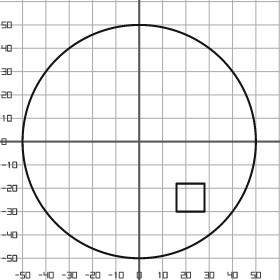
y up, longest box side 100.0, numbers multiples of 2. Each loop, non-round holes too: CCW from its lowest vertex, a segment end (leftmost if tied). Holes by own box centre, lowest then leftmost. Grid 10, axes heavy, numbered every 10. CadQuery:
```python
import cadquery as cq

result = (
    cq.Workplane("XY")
    .moveTo(0.0, 0.0)
    .circle(50.0)
    .moveTo(16.0, -30.0)
    .lineTo(28.0, -30.0)
    .lineTo(28.0, -18.0)
    .lineTo(16.0, -18.0)
    .close()
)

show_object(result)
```